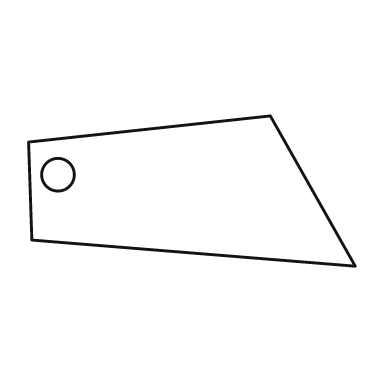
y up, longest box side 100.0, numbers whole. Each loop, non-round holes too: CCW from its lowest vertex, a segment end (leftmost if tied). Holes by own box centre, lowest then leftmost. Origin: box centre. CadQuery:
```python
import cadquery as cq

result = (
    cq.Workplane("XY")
    .moveTo(50.0, -23.0)
    .lineTo(24.0, 23.0)
    .lineTo(-50.0, 15.0)
    .lineTo(-49.0, -15.0)
    .close()
    .moveTo(-41.0, 5.0)
    .circle(5.0)
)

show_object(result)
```